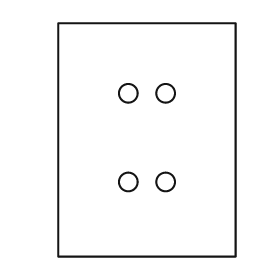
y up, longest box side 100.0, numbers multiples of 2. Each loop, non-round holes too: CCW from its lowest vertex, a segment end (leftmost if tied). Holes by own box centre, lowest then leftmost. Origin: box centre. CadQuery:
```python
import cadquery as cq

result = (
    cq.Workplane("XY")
    .moveTo(-38.0, -50.0)
    .lineTo(38.0, -50.0)
    .lineTo(38.0, 50.0)
    .lineTo(-38.0, 50.0)
    .close()
    .moveTo(-8.0, -18.0)
    .circle(4.0)
    .moveTo(8.0, -18.0)
    .circle(4.0)
    .moveTo(-8.0, 20.0)
    .circle(4.0)
    .moveTo(8.0, 20.0)
    .circle(4.0)
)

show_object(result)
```